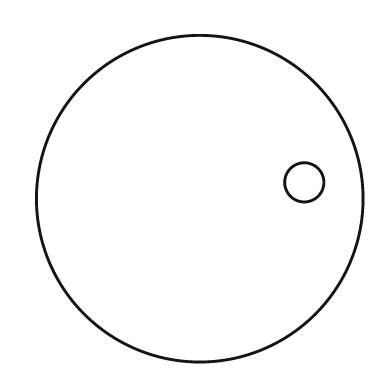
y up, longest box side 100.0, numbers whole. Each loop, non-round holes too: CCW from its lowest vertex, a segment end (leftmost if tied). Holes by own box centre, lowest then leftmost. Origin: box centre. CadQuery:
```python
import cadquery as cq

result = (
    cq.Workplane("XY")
    .moveTo(0.0, 0.0)
    .circle(50.0)
    .moveTo(32.0, 5.0)
    .circle(6.0)
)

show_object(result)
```